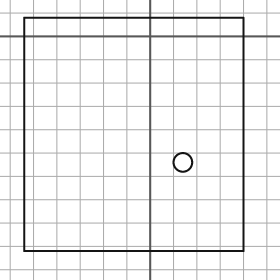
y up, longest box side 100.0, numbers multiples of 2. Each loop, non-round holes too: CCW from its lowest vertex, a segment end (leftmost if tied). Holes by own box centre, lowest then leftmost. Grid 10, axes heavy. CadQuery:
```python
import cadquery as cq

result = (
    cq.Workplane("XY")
    .moveTo(-54.0, -92.0)
    .lineTo(40.0, -92.0)
    .lineTo(40.0, 8.0)
    .lineTo(-54.0, 8.0)
    .close()
    .moveTo(14.0, -54.0)
    .circle(4.0)
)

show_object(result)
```